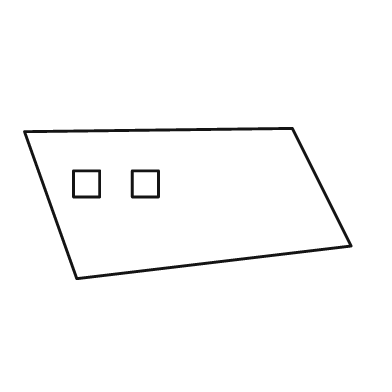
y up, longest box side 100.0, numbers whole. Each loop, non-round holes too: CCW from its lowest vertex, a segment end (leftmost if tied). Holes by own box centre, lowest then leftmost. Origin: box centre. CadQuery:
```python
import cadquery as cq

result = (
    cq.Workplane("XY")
    .moveTo(-34.0, -23.0)
    .lineTo(50.0, -13.0)
    .lineTo(32.0, 23.0)
    .lineTo(-50.0, 22.0)
    .close()
    .moveTo(-35.0, 2.0)
    .lineTo(-27.0, 2.0)
    .lineTo(-27.0, 10.0)
    .lineTo(-35.0, 10.0)
    .close()
    .moveTo(-17.0, 2.0)
    .lineTo(-9.0, 2.0)
    .lineTo(-9.0, 10.0)
    .lineTo(-17.0, 10.0)
    .close()
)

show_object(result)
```